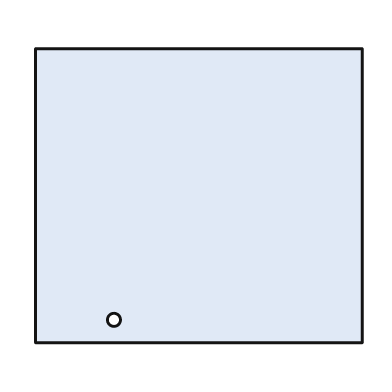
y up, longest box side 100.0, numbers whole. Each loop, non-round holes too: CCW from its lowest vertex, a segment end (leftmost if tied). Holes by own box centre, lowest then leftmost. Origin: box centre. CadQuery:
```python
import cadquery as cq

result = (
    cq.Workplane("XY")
    .moveTo(-50.0, -45.0)
    .lineTo(50.0, -45.0)
    .lineTo(50.0, 45.0)
    .lineTo(-50.0, 45.0)
    .close()
    .moveTo(-26.0, -38.0)
    .circle(2.0)
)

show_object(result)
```